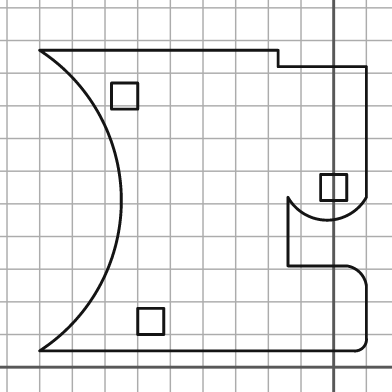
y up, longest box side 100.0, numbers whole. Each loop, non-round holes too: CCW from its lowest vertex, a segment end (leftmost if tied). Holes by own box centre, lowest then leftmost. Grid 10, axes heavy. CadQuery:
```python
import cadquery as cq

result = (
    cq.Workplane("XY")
    .moveTo(-90.0, 5.0)
    .lineTo(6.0, 5.0)
    .threePointArc((9.0, 6.0), (10.0, 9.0))
    .lineTo(10.0, 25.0)
    .threePointArc((8.0, 29.0), (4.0, 31.0))
    .lineTo(-14.0, 31.0)
    .lineTo(-14.0, 52.0)
    .threePointArc((-2.0, 45.0), (10.0, 52.0))
    .lineTo(10.0, 92.0)
    .lineTo(-17.0, 92.0)
    .lineTo(-17.0, 97.0)
    .lineTo(-90.0, 97.0)
    .threePointArc((-65.0, 51.0), (-90.0, 5.0))
    .close()
    .moveTo(-60.0, 10.0)
    .lineTo(-52.0, 10.0)
    .lineTo(-52.0, 18.0)
    .lineTo(-60.0, 18.0)
    .close()
    .moveTo(-4.0, 51.0)
    .lineTo(4.0, 51.0)
    .lineTo(4.0, 59.0)
    .lineTo(-4.0, 59.0)
    .close()
    .moveTo(-68.0, 79.0)
    .lineTo(-60.0, 79.0)
    .lineTo(-60.0, 87.0)
    .lineTo(-68.0, 87.0)
    .close()
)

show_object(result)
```